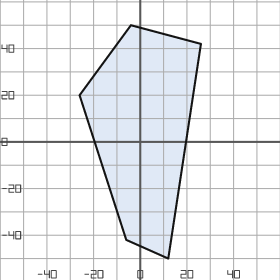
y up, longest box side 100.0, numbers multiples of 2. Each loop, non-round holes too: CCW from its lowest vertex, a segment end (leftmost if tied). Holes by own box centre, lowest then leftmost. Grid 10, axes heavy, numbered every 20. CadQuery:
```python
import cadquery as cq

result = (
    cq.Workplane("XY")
    .moveTo(12.0, -50.0)
    .lineTo(26.0, 42.0)
    .lineTo(-4.0, 50.0)
    .lineTo(-26.0, 20.0)
    .lineTo(-6.0, -42.0)
    .close()
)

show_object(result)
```